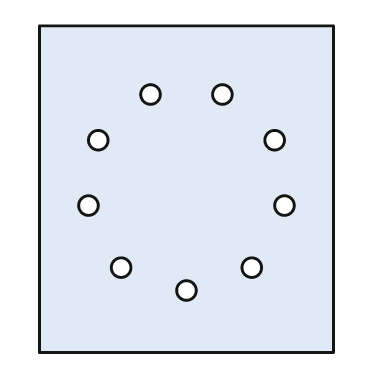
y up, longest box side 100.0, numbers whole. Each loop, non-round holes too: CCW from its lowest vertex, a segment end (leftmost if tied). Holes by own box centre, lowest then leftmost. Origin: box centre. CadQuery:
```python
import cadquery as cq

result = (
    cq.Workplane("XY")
    .moveTo(-45.0, -50.0)
    .lineTo(45.0, -50.0)
    .lineTo(45.0, 50.0)
    .lineTo(-45.0, 50.0)
    .close()
    .moveTo(0.0, -31.0)
    .circle(3.0)
    .moveTo(-20.0, -24.0)
    .circle(3.0)
    .moveTo(20.0, -24.0)
    .circle(3.0)
    .moveTo(-30.0, -5.0)
    .circle(3.0)
    .moveTo(30.0, -5.0)
    .circle(3.0)
    .moveTo(-27.0, 15.0)
    .circle(3.0)
    .moveTo(27.0, 15.0)
    .circle(3.0)
    .moveTo(-11.0, 29.0)
    .circle(3.0)
    .moveTo(11.0, 29.0)
    .circle(3.0)
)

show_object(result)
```